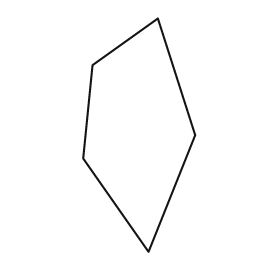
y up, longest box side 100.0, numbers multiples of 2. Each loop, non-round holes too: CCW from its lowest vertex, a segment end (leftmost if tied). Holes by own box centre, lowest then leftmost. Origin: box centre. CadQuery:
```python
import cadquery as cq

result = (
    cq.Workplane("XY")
    .moveTo(4.0, -50.0)
    .lineTo(24.0, 0.0)
    .lineTo(8.0, 50.0)
    .lineTo(-20.0, 30.0)
    .lineTo(-24.0, -10.0)
    .close()
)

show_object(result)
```